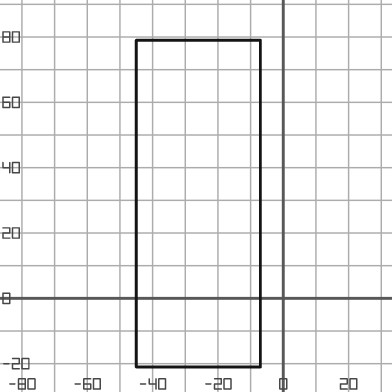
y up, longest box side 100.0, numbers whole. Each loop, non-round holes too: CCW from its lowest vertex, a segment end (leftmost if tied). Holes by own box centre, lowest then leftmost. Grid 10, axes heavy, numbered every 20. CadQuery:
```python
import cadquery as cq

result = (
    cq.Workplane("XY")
    .moveTo(-45.0, -21.0)
    .lineTo(-7.0, -21.0)
    .lineTo(-7.0, 79.0)
    .lineTo(-45.0, 79.0)
    .close()
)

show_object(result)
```